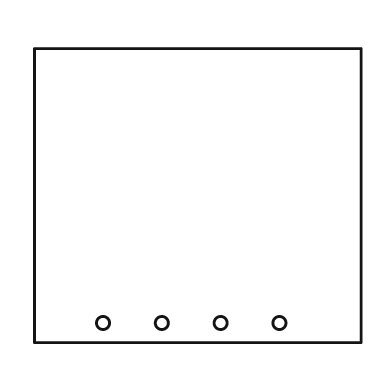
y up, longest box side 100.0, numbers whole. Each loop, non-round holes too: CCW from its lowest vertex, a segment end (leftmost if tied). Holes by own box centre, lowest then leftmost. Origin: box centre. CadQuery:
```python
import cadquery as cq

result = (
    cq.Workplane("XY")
    .moveTo(-50.0, -45.0)
    .lineTo(50.0, -45.0)
    .lineTo(50.0, 45.0)
    .lineTo(-50.0, 45.0)
    .close()
    .moveTo(-29.0, -39.0)
    .circle(2.0)
    .moveTo(-11.0, -39.0)
    .circle(2.0)
    .moveTo(7.0, -39.0)
    .circle(2.0)
    .moveTo(25.0, -39.0)
    .circle(2.0)
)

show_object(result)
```